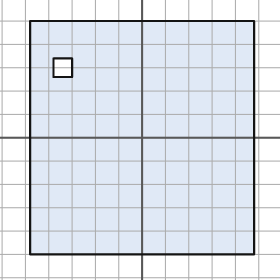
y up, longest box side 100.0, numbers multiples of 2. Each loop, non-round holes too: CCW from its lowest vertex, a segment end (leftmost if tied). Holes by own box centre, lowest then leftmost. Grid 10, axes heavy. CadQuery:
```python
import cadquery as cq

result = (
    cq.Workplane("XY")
    .moveTo(-48.0, -50.0)
    .lineTo(48.0, -50.0)
    .lineTo(48.0, 50.0)
    .lineTo(-48.0, 50.0)
    .close()
    .moveTo(-38.0, 26.0)
    .lineTo(-30.0, 26.0)
    .lineTo(-30.0, 34.0)
    .lineTo(-38.0, 34.0)
    .close()
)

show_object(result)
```